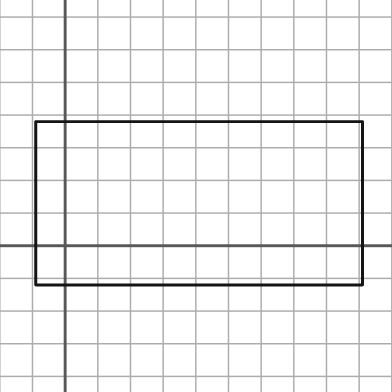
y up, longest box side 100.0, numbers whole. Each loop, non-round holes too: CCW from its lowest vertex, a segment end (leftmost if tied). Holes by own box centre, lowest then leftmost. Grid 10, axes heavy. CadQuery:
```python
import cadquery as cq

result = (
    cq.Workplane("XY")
    .moveTo(-9.0, -12.0)
    .lineTo(91.0, -12.0)
    .lineTo(91.0, 38.0)
    .lineTo(-9.0, 38.0)
    .close()
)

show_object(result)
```